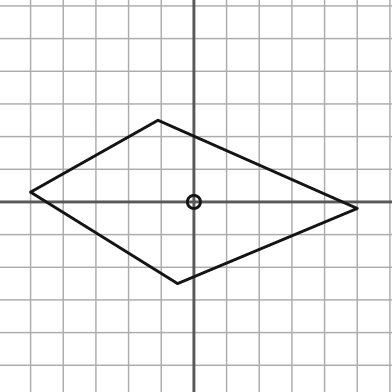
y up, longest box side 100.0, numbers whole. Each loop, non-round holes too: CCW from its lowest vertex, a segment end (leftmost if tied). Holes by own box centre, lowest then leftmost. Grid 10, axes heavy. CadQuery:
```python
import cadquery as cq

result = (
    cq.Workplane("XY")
    .moveTo(-5.0, -25.0)
    .lineTo(50.0, -2.0)
    .lineTo(-11.0, 25.0)
    .lineTo(-50.0, 3.0)
    .close()
    .moveTo(0.0, 0.0)
    .circle(2.0)
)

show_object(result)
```